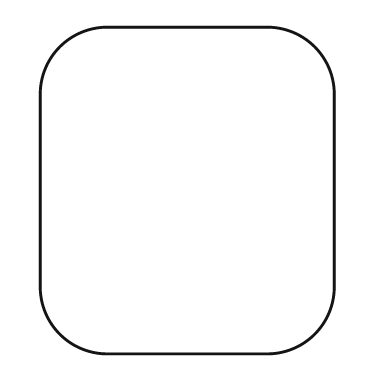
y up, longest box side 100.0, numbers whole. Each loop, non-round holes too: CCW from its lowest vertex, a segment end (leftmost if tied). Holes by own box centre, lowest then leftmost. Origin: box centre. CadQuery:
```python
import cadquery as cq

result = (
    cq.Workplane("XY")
    .moveTo(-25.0, -50.0)
    .lineTo(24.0, -50.0)
    .threePointArc((39.0, -44.0), (45.0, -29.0))
    .lineTo(45.0, 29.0)
    .threePointArc((39.0, 44.0), (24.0, 50.0))
    .lineTo(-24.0, 50.0)
    .threePointArc((-39.0, 44.0), (-45.0, 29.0))
    .lineTo(-45.0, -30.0)
    .threePointArc((-39.0, -44.0), (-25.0, -50.0))
    .close()
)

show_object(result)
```